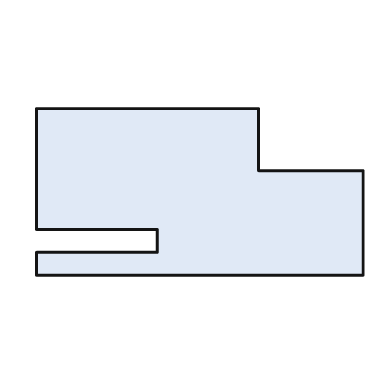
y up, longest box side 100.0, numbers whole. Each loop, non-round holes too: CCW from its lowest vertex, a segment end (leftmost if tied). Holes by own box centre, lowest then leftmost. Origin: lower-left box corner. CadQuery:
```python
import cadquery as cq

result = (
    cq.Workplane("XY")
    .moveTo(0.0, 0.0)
    .lineTo(100.0, 0.0)
    .lineTo(100.0, 32.0)
    .lineTo(68.0, 32.0)
    .lineTo(68.0, 51.0)
    .lineTo(0.0, 51.0)
    .lineTo(0.0, 14.0)
    .lineTo(37.0, 14.0)
    .lineTo(37.0, 7.0)
    .lineTo(0.0, 7.0)
    .close()
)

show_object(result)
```